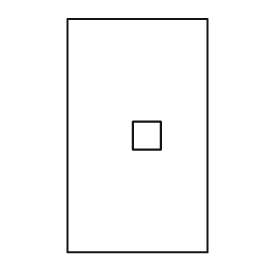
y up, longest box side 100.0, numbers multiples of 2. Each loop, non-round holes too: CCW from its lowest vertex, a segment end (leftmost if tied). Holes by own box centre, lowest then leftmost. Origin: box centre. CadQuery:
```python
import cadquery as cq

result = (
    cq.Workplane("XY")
    .moveTo(-30.0, -50.0)
    .lineTo(30.0, -50.0)
    .lineTo(30.0, 50.0)
    .lineTo(-30.0, 50.0)
    .close()
    .moveTo(-2.0, -6.0)
    .lineTo(10.0, -6.0)
    .lineTo(10.0, 6.0)
    .lineTo(-2.0, 6.0)
    .close()
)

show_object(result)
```